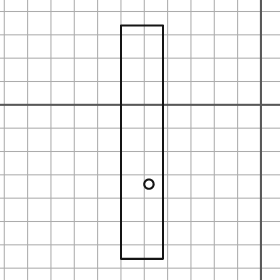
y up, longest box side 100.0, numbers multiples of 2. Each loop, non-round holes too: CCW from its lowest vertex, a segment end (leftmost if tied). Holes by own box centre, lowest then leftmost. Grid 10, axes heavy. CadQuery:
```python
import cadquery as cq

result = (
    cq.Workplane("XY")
    .moveTo(-60.0, -66.0)
    .lineTo(-42.0, -66.0)
    .lineTo(-42.0, 34.0)
    .lineTo(-60.0, 34.0)
    .close()
    .moveTo(-48.0, -34.0)
    .circle(2.0)
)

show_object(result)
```